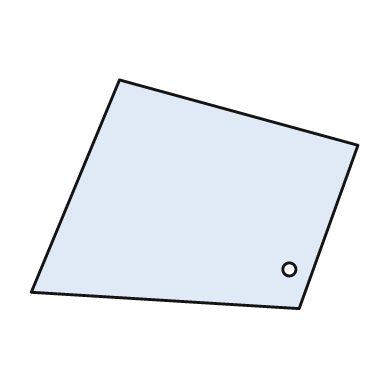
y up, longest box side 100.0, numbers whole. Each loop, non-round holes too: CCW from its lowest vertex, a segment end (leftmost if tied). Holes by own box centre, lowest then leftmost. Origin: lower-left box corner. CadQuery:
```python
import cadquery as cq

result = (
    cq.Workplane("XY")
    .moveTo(82.0, 0.0)
    .lineTo(100.0, 50.0)
    .lineTo(27.0, 70.0)
    .lineTo(0.0, 5.0)
    .close()
    .moveTo(79.0, 12.0)
    .circle(2.0)
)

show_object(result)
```